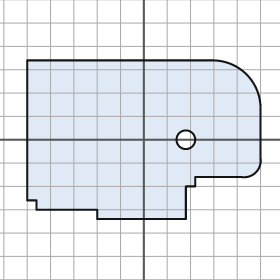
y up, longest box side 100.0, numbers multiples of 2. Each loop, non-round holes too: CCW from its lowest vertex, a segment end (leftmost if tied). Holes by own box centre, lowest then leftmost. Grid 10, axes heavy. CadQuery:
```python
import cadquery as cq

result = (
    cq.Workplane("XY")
    .moveTo(-20.0, -34.0)
    .lineTo(18.0, -34.0)
    .lineTo(18.0, -20.0)
    .lineTo(22.0, -20.0)
    .lineTo(22.0, -16.0)
    .lineTo(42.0, -16.0)
    .threePointArc((48.0, -14.0), (50.0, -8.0))
    .lineTo(50.0, 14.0)
    .threePointArc((44.0, 28.0), (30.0, 34.0))
    .lineTo(-50.0, 34.0)
    .lineTo(-50.0, -26.0)
    .lineTo(-46.0, -26.0)
    .lineTo(-46.0, -30.0)
    .lineTo(-20.0, -30.0)
    .close()
    .moveTo(18.0, 0.0)
    .circle(4.0)
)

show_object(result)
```